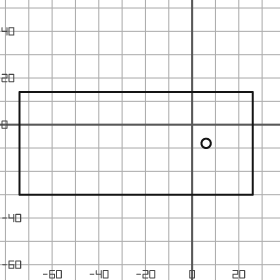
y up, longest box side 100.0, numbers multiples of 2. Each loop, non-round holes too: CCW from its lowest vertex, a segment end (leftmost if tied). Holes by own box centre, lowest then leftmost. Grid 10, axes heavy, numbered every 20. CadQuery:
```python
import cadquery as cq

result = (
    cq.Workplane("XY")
    .moveTo(-74.0, -30.0)
    .lineTo(26.0, -30.0)
    .lineTo(26.0, 14.0)
    .lineTo(-74.0, 14.0)
    .close()
    .moveTo(6.0, -8.0)
    .circle(2.0)
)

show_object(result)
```